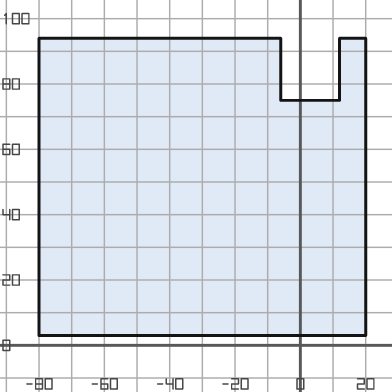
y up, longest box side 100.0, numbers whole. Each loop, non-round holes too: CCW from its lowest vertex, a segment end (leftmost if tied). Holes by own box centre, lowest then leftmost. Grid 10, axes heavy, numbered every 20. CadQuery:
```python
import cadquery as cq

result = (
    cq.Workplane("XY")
    .moveTo(-80.0, 3.0)
    .lineTo(20.0, 3.0)
    .lineTo(20.0, 94.0)
    .lineTo(12.0, 94.0)
    .lineTo(12.0, 75.0)
    .lineTo(-6.0, 75.0)
    .lineTo(-6.0, 94.0)
    .lineTo(-80.0, 94.0)
    .close()
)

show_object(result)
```